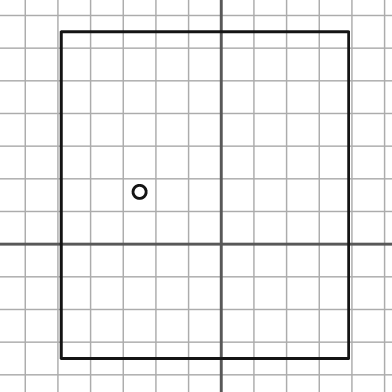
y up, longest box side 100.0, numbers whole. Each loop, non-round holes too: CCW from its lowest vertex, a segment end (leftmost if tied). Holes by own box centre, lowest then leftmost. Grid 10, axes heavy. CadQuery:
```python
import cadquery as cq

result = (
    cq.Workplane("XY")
    .moveTo(-49.0, -35.0)
    .lineTo(39.0, -35.0)
    .lineTo(39.0, 65.0)
    .lineTo(-49.0, 65.0)
    .close()
    .moveTo(-25.0, 16.0)
    .circle(2.0)
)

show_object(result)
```